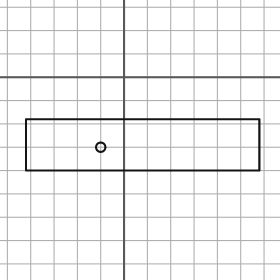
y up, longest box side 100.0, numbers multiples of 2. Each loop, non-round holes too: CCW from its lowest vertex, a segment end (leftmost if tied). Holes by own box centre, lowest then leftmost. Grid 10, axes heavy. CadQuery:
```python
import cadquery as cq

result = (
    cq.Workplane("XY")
    .moveTo(-42.0, -40.0)
    .lineTo(58.0, -40.0)
    .lineTo(58.0, -18.0)
    .lineTo(-42.0, -18.0)
    .close()
    .moveTo(-10.0, -30.0)
    .circle(2.0)
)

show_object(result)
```